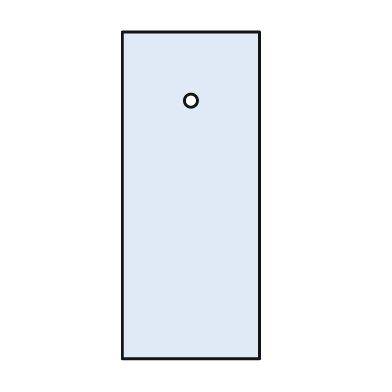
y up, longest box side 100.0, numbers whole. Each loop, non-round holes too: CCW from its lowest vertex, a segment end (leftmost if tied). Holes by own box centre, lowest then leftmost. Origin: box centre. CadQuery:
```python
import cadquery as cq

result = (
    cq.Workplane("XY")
    .moveTo(-21.0, -50.0)
    .lineTo(21.0, -50.0)
    .lineTo(21.0, 50.0)
    .lineTo(-21.0, 50.0)
    .close()
    .moveTo(0.0, 29.0)
    .circle(2.0)
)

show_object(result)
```